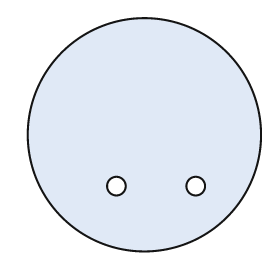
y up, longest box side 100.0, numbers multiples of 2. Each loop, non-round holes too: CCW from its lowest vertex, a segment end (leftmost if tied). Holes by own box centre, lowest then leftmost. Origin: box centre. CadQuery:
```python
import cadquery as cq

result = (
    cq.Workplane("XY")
    .moveTo(0.0, 0.0)
    .circle(50.0)
    .moveTo(-12.0, -22.0)
    .circle(4.0)
    .moveTo(22.0, -22.0)
    .circle(4.0)
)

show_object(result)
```